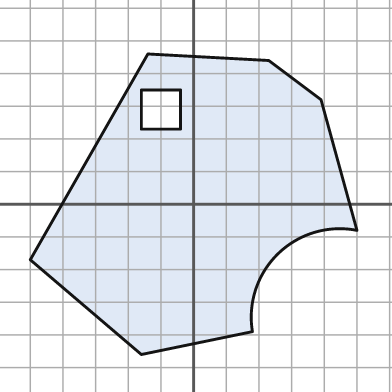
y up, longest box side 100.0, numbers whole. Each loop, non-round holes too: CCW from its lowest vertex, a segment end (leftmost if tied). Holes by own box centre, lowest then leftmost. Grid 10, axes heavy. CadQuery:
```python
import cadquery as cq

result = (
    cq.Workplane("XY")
    .moveTo(-16.0, -46.0)
    .lineTo(18.0, -39.0)
    .threePointArc((26.0, -15.0), (50.0, -8.0))
    .lineTo(39.0, 32.0)
    .lineTo(23.0, 44.0)
    .lineTo(-14.0, 46.0)
    .lineTo(-50.0, -17.0)
    .close()
    .moveTo(-16.0, 23.0)
    .lineTo(-4.0, 23.0)
    .lineTo(-4.0, 35.0)
    .lineTo(-16.0, 35.0)
    .close()
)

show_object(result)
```